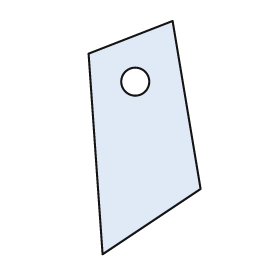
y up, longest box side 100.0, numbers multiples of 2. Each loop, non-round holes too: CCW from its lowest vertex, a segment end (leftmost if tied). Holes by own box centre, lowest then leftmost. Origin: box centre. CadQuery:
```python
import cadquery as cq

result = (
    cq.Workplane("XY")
    .moveTo(-18.0, -50.0)
    .lineTo(24.0, -22.0)
    .lineTo(12.0, 50.0)
    .lineTo(-24.0, 36.0)
    .close()
    .moveTo(-4.0, 24.0)
    .circle(6.0)
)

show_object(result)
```